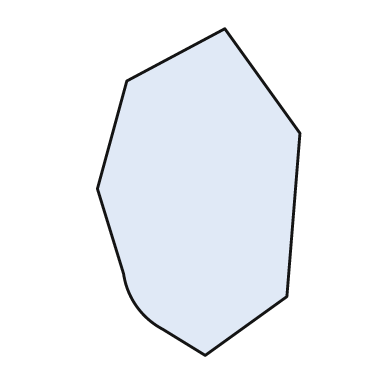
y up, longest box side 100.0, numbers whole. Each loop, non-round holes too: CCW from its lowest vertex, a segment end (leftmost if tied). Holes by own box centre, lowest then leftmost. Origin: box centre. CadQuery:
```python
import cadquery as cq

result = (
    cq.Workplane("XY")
    .moveTo(2.0, -50.0)
    .lineTo(27.0, -32.0)
    .lineTo(31.0, 18.0)
    .lineTo(8.0, 50.0)
    .lineTo(-22.0, 34.0)
    .lineTo(-31.0, 1.0)
    .lineTo(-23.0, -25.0)
    .threePointArc((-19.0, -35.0), (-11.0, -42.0))
    .close()
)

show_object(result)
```